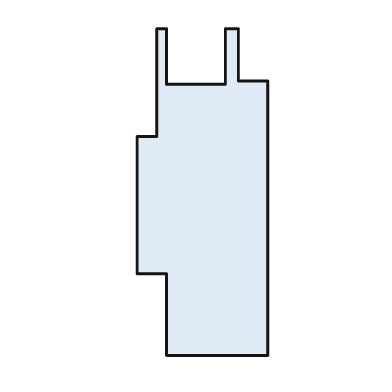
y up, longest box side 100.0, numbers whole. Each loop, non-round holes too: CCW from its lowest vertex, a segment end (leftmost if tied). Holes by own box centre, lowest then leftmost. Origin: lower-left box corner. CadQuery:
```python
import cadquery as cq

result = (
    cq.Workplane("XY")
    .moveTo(9.0, 0.0)
    .lineTo(40.0, 0.0)
    .lineTo(40.0, 84.0)
    .lineTo(31.0, 84.0)
    .lineTo(31.0, 100.0)
    .lineTo(27.0, 100.0)
    .lineTo(27.0, 83.0)
    .lineTo(9.0, 83.0)
    .lineTo(9.0, 100.0)
    .lineTo(6.0, 100.0)
    .lineTo(6.0, 67.0)
    .lineTo(0.0, 67.0)
    .lineTo(0.0, 25.0)
    .lineTo(9.0, 25.0)
    .close()
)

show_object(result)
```